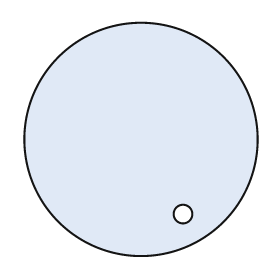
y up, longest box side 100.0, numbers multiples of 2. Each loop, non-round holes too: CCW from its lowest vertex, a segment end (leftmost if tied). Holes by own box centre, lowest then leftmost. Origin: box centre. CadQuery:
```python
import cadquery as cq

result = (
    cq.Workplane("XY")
    .moveTo(0.0, 0.0)
    .circle(50.0)
    .moveTo(18.0, -32.0)
    .circle(4.0)
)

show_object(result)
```